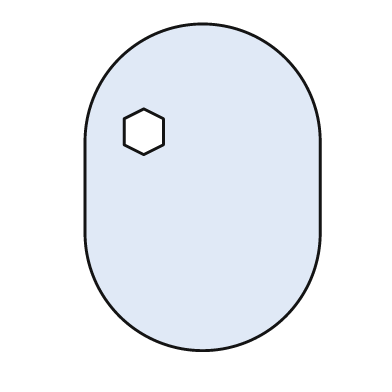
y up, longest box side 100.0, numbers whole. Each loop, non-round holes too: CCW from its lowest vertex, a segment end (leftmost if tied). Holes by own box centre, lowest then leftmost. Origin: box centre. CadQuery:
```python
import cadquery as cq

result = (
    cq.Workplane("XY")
    .moveTo(-36.0, -14.0)
    .threePointArc((0.0, -50.0), (36.0, -14.0))
    .lineTo(36.0, 14.0)
    .threePointArc((0.0, 50.0), (-36.0, 14.0))
    .close()
    .moveTo(-18.0, 10.0)
    .lineTo(-12.0, 13.0)
    .lineTo(-12.0, 21.0)
    .lineTo(-18.0, 24.0)
    .lineTo(-24.0, 21.0)
    .lineTo(-24.0, 13.0)
    .close()
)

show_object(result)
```